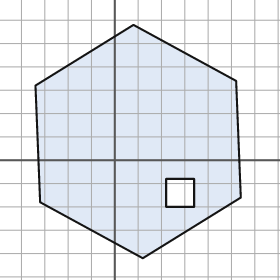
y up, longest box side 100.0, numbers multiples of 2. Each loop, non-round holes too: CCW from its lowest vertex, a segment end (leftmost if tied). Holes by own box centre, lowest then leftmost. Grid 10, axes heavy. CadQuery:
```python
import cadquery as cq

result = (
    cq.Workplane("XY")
    .moveTo(12.0, -42.0)
    .lineTo(54.0, -16.0)
    .lineTo(52.0, 34.0)
    .lineTo(8.0, 58.0)
    .lineTo(-34.0, 32.0)
    .lineTo(-32.0, -18.0)
    .close()
    .moveTo(22.0, -20.0)
    .lineTo(34.0, -20.0)
    .lineTo(34.0, -8.0)
    .lineTo(22.0, -8.0)
    .close()
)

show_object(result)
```